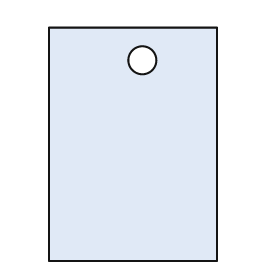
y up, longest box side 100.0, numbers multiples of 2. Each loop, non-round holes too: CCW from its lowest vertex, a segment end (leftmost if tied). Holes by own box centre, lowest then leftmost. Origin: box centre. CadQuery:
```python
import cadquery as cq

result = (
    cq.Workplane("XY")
    .moveTo(-36.0, -50.0)
    .lineTo(36.0, -50.0)
    .lineTo(36.0, 50.0)
    .lineTo(-36.0, 50.0)
    .close()
    .moveTo(4.0, 36.0)
    .circle(6.0)
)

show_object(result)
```